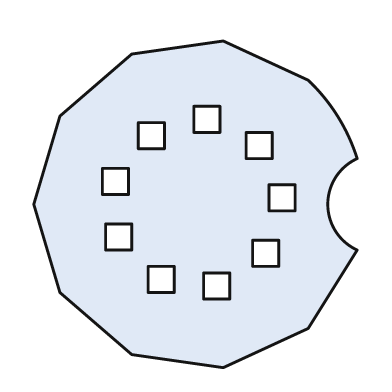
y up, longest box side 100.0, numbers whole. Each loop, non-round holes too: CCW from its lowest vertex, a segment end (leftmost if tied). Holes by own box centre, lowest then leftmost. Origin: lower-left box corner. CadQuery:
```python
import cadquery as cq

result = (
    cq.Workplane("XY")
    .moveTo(58.0, 0.0)
    .lineTo(84.0, 12.0)
    .lineTo(99.0, 36.0)
    .threePointArc((90.0, 50.0), (99.0, 64.0))
    .threePointArc((93.0, 77.0), (84.0, 88.0))
    .lineTo(58.0, 100.0)
    .lineTo(30.0, 96.0)
    .lineTo(8.0, 77.0)
    .lineTo(0.0, 50.0)
    .lineTo(8.0, 23.0)
    .lineTo(30.0, 4.0)
    .close()
    .moveTo(52.0, 21.0)
    .lineTo(60.0, 21.0)
    .lineTo(60.0, 29.0)
    .lineTo(52.0, 29.0)
    .close()
    .moveTo(35.0, 23.0)
    .lineTo(43.0, 23.0)
    .lineTo(43.0, 31.0)
    .lineTo(35.0, 31.0)
    .close()
    .moveTo(67.0, 31.0)
    .lineTo(75.0, 31.0)
    .lineTo(75.0, 39.0)
    .lineTo(67.0, 39.0)
    .close()
    .moveTo(22.0, 36.0)
    .lineTo(30.0, 36.0)
    .lineTo(30.0, 44.0)
    .lineTo(22.0, 44.0)
    .close()
    .moveTo(72.0, 48.0)
    .lineTo(80.0, 48.0)
    .lineTo(80.0, 56.0)
    .lineTo(72.0, 56.0)
    .close()
    .moveTo(21.0, 53.0)
    .lineTo(29.0, 53.0)
    .lineTo(29.0, 61.0)
    .lineTo(21.0, 61.0)
    .close()
    .moveTo(65.0, 64.0)
    .lineTo(73.0, 64.0)
    .lineTo(73.0, 72.0)
    .lineTo(65.0, 72.0)
    .close()
    .moveTo(32.0, 67.0)
    .lineTo(40.0, 67.0)
    .lineTo(40.0, 75.0)
    .lineTo(32.0, 75.0)
    .close()
    .moveTo(49.0, 72.0)
    .lineTo(57.0, 72.0)
    .lineTo(57.0, 80.0)
    .lineTo(49.0, 80.0)
    .close()
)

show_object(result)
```